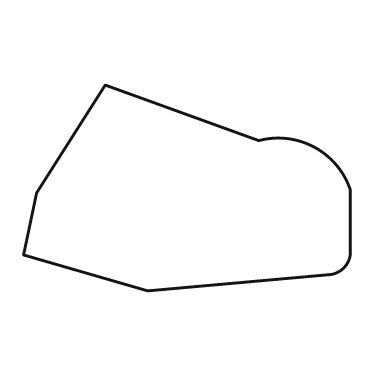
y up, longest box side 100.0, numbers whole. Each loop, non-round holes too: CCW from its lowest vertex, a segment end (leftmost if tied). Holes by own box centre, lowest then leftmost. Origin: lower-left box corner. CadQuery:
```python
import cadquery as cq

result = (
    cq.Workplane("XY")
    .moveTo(38.0, 0.0)
    .lineTo(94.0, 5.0)
    .threePointArc((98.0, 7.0), (100.0, 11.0))
    .lineTo(100.0, 31.0)
    .threePointArc((89.0, 44.0), (72.0, 46.0))
    .lineTo(25.0, 63.0)
    .lineTo(4.0, 30.0)
    .lineTo(0.0, 11.0)
    .close()
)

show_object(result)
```